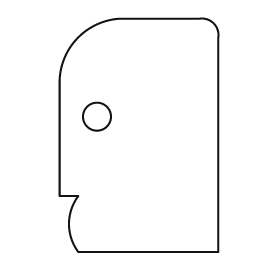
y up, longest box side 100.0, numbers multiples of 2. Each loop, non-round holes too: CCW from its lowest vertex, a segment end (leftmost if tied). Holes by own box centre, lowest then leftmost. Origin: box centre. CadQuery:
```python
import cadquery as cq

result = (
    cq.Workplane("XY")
    .moveTo(-26.0, -50.0)
    .lineTo(34.0, -50.0)
    .lineTo(34.0, 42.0)
    .threePointArc((32.0, 48.0), (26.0, 50.0))
    .lineTo(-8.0, 50.0)
    .threePointArc((-26.0, 42.0), (-34.0, 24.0))
    .lineTo(-34.0, -26.0)
    .lineTo(-26.0, -26.0)
    .threePointArc((-30.0, -38.0), (-26.0, -50.0))
    .close()
    .moveTo(-18.0, 8.0)
    .circle(6.0)
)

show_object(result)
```